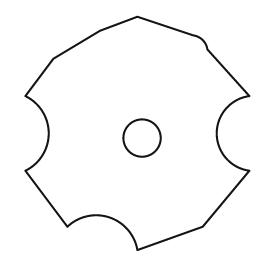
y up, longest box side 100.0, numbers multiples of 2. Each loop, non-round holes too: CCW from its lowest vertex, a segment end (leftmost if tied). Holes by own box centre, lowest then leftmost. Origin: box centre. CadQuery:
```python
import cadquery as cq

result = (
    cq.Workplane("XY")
    .moveTo(0.0, -50.0)
    .lineTo(28.0, -40.0)
    .lineTo(48.0, -16.0)
    .threePointArc((34.0, 0.0), (48.0, 16.0))
    .lineTo(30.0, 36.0)
    .threePointArc((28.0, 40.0), (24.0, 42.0))
    .lineTo(0.0, 50.0)
    .lineTo(-16.0, 44.0)
    .lineTo(-36.0, 32.0)
    .lineTo(-48.0, 16.0)
    .threePointArc((-38.0, 0.0), (-48.0, -16.0))
    .lineTo(-30.0, -40.0)
    .threePointArc((-12.0, -36.0), (0.0, -50.0))
    .close()
    .moveTo(2.0, -2.0)
    .circle(8.0)
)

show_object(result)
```